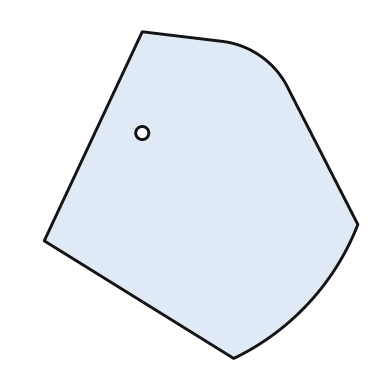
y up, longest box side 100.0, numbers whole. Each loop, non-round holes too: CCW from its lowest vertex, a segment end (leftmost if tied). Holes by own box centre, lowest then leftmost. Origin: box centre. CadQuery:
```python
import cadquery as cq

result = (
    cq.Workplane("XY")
    .moveTo(10.0, -50.0)
    .threePointArc((33.0, -33.0), (48.0, -9.0))
    .lineTo(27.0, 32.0)
    .threePointArc((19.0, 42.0), (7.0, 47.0))
    .lineTo(-18.0, 50.0)
    .lineTo(-48.0, -14.0)
    .close()
    .moveTo(-18.0, 19.0)
    .circle(2.0)
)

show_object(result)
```